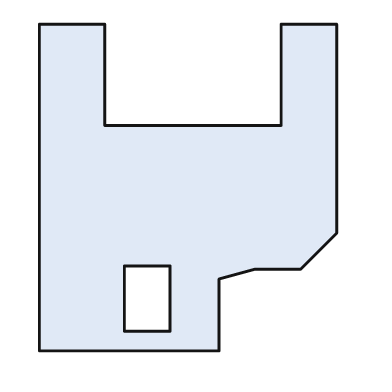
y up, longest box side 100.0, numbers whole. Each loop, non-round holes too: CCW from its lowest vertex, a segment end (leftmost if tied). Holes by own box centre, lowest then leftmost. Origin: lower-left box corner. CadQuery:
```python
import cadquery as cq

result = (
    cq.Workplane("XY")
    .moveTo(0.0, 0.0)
    .lineTo(55.0, 0.0)
    .lineTo(55.0, 22.0)
    .lineTo(66.0, 25.0)
    .lineTo(80.0, 25.0)
    .lineTo(91.0, 36.0)
    .lineTo(91.0, 100.0)
    .lineTo(74.0, 100.0)
    .lineTo(74.0, 69.0)
    .lineTo(20.0, 69.0)
    .lineTo(20.0, 100.0)
    .lineTo(0.0, 100.0)
    .close()
    .moveTo(26.0, 6.0)
    .lineTo(40.0, 6.0)
    .lineTo(40.0, 26.0)
    .lineTo(26.0, 26.0)
    .close()
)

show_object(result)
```